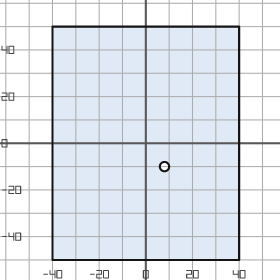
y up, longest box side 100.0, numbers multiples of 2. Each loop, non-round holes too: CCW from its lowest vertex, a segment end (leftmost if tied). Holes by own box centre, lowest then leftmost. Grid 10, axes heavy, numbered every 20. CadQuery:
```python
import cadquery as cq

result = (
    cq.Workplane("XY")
    .moveTo(-40.0, -50.0)
    .lineTo(40.0, -50.0)
    .lineTo(40.0, 50.0)
    .lineTo(-40.0, 50.0)
    .close()
    .moveTo(8.0, -10.0)
    .circle(2.0)
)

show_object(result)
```